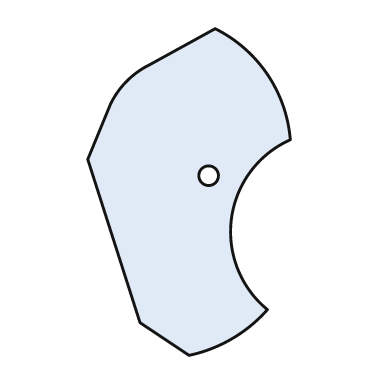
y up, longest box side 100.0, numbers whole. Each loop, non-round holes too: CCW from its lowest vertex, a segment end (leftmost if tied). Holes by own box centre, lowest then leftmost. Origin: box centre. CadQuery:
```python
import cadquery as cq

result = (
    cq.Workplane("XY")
    .moveTo(0.0, -50.0)
    .threePointArc((13.0, -45.0), (24.0, -36.0))
    .threePointArc((13.0, -8.0), (31.0, 16.0))
    .threePointArc((24.0, 36.0), (8.0, 50.0))
    .lineTo(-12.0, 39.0)
    .threePointArc((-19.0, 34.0), (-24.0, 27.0))
    .lineTo(-31.0, 10.0)
    .lineTo(-15.0, -40.0)
    .close()
    .moveTo(6.0, 5.0)
    .circle(3.0)
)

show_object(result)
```